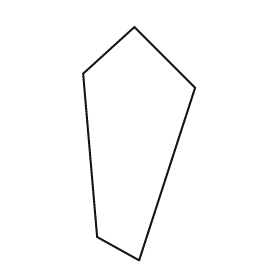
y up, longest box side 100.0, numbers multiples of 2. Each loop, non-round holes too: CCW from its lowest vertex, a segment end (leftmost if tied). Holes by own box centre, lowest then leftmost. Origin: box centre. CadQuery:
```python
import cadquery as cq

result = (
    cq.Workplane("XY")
    .moveTo(0.0, -50.0)
    .lineTo(24.0, 24.0)
    .lineTo(-2.0, 50.0)
    .lineTo(-24.0, 30.0)
    .lineTo(-18.0, -40.0)
    .close()
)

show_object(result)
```